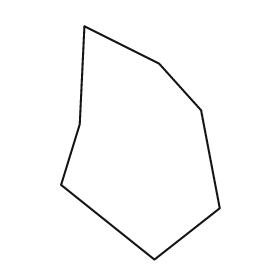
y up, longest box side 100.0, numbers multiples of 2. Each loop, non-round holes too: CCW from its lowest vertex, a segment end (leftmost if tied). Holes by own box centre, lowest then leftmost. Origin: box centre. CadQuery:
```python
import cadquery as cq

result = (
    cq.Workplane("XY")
    .moveTo(6.0, -50.0)
    .lineTo(34.0, -28.0)
    .lineTo(26.0, 14.0)
    .lineTo(8.0, 34.0)
    .lineTo(-24.0, 50.0)
    .lineTo(-26.0, 8.0)
    .lineTo(-34.0, -18.0)
    .close()
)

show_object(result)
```